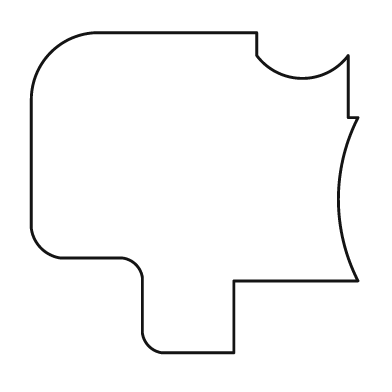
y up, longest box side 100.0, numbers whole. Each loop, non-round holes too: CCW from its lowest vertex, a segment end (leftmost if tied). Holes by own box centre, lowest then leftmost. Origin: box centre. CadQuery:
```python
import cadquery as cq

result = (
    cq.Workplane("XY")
    .moveTo(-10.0, -49.0)
    .lineTo(12.0, -49.0)
    .lineTo(12.0, -27.0)
    .lineTo(50.0, -27.0)
    .threePointArc((44.0, -2.0), (50.0, 23.0))
    .lineTo(47.0, 23.0)
    .lineTo(47.0, 42.0)
    .threePointArc((33.0, 35.0), (19.0, 42.0))
    .lineTo(19.0, 49.0)
    .lineTo(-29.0, 49.0)
    .threePointArc((-44.0, 43.0), (-50.0, 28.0))
    .lineTo(-50.0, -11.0)
    .threePointArc((-47.0, -17.0), (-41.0, -20.0))
    .lineTo(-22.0, -20.0)
    .threePointArc((-18.0, -22.0), (-16.0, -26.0))
    .lineTo(-16.0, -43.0)
    .threePointArc((-14.0, -47.0), (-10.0, -49.0))
    .close()
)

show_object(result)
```